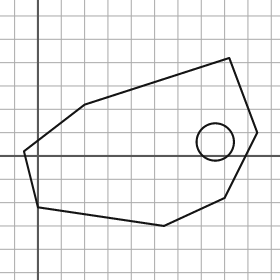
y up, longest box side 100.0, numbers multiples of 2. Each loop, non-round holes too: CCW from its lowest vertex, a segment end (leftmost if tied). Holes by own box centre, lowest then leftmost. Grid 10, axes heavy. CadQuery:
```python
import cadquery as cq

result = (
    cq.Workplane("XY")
    .moveTo(54.0, -30.0)
    .lineTo(80.0, -18.0)
    .lineTo(94.0, 10.0)
    .lineTo(82.0, 42.0)
    .lineTo(20.0, 22.0)
    .lineTo(-6.0, 2.0)
    .lineTo(0.0, -22.0)
    .close()
    .moveTo(76.0, 6.0)
    .circle(8.0)
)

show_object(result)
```